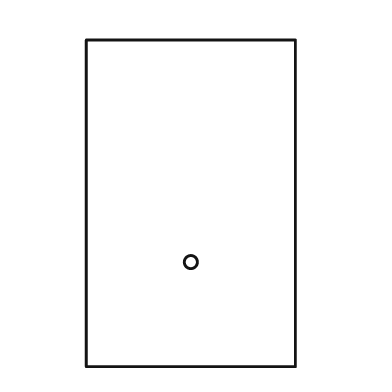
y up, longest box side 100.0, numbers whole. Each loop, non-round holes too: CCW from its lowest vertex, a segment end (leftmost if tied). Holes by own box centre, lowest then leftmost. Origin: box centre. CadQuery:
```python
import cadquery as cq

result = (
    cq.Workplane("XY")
    .moveTo(-32.0, -50.0)
    .lineTo(32.0, -50.0)
    .lineTo(32.0, 50.0)
    .lineTo(-32.0, 50.0)
    .close()
    .moveTo(0.0, -18.0)
    .circle(2.0)
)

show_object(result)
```